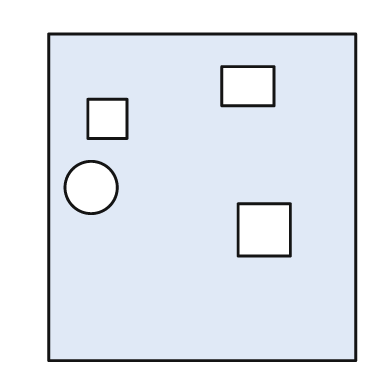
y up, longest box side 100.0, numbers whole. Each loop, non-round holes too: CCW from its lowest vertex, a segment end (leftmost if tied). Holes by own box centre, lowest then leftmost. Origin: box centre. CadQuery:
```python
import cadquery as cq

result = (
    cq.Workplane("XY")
    .moveTo(-47.0, -50.0)
    .lineTo(47.0, -50.0)
    .lineTo(47.0, 50.0)
    .lineTo(-47.0, 50.0)
    .close()
    .moveTo(11.0, -18.0)
    .lineTo(27.0, -18.0)
    .lineTo(27.0, -2.0)
    .lineTo(11.0, -2.0)
    .close()
    .moveTo(-34.0, 3.0)
    .circle(8.0)
    .moveTo(-35.0, 18.0)
    .lineTo(-23.0, 18.0)
    .lineTo(-23.0, 30.0)
    .lineTo(-35.0, 30.0)
    .close()
    .moveTo(6.0, 28.0)
    .lineTo(22.0, 28.0)
    .lineTo(22.0, 40.0)
    .lineTo(6.0, 40.0)
    .close()
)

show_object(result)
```